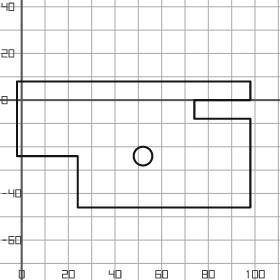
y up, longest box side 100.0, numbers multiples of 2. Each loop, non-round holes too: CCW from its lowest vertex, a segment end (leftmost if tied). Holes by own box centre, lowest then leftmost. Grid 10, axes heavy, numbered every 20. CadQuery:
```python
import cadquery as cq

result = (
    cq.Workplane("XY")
    .moveTo(24.0, -46.0)
    .lineTo(98.0, -46.0)
    .lineTo(98.0, -8.0)
    .lineTo(74.0, -8.0)
    .lineTo(74.0, 0.0)
    .lineTo(98.0, 0.0)
    .lineTo(98.0, 8.0)
    .lineTo(-2.0, 8.0)
    .lineTo(-2.0, -24.0)
    .lineTo(24.0, -24.0)
    .close()
    .moveTo(52.0, -24.0)
    .circle(4.0)
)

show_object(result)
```